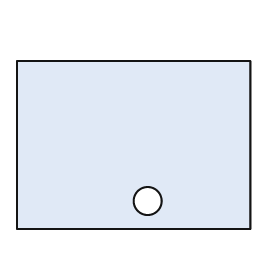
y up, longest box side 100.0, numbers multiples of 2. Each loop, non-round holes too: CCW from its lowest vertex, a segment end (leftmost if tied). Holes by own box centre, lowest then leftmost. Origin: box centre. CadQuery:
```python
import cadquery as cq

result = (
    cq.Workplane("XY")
    .moveTo(-50.0, -36.0)
    .lineTo(50.0, -36.0)
    .lineTo(50.0, 36.0)
    .lineTo(-50.0, 36.0)
    .close()
    .moveTo(6.0, -24.0)
    .circle(6.0)
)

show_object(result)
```